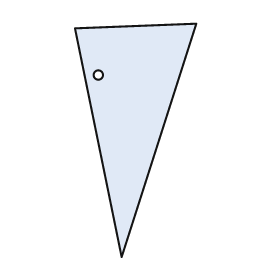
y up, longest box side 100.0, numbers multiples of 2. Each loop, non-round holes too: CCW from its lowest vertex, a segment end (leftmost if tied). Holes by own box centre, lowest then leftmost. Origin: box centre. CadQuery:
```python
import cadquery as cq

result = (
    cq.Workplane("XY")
    .moveTo(-6.0, -50.0)
    .lineTo(26.0, 50.0)
    .lineTo(-26.0, 48.0)
    .close()
    .moveTo(-16.0, 28.0)
    .circle(2.0)
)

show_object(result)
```